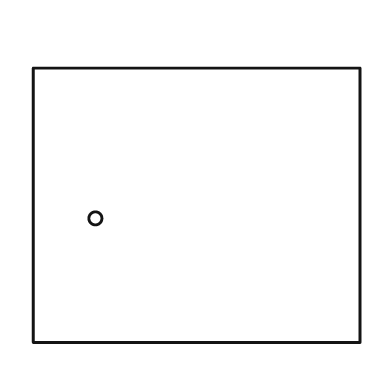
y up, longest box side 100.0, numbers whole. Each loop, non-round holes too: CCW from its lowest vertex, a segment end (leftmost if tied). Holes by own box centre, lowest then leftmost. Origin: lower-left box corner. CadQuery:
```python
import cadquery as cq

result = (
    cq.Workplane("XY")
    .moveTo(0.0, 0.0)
    .lineTo(100.0, 0.0)
    .lineTo(100.0, 84.0)
    .lineTo(0.0, 84.0)
    .close()
    .moveTo(19.0, 38.0)
    .circle(2.0)
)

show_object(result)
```